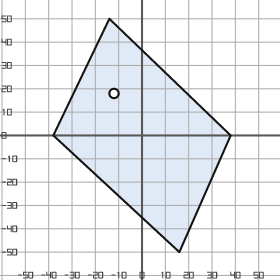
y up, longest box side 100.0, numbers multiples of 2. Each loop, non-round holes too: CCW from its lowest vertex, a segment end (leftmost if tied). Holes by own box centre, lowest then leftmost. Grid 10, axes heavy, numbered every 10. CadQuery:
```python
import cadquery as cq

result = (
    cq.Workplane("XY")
    .moveTo(16.0, -50.0)
    .lineTo(38.0, 0.0)
    .lineTo(-14.0, 50.0)
    .lineTo(-38.0, 0.0)
    .close()
    .moveTo(-12.0, 18.0)
    .circle(2.0)
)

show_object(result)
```